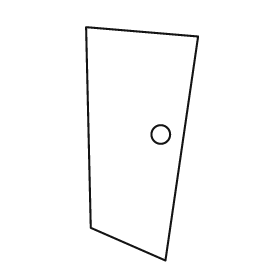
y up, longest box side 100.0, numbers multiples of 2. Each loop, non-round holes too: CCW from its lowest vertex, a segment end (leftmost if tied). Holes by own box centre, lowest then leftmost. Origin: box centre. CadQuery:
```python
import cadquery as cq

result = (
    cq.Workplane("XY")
    .moveTo(10.0, -50.0)
    .lineTo(24.0, 46.0)
    .lineTo(-24.0, 50.0)
    .lineTo(-22.0, -36.0)
    .close()
    .moveTo(8.0, 4.0)
    .circle(4.0)
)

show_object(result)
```